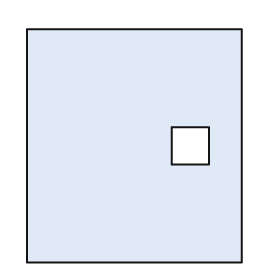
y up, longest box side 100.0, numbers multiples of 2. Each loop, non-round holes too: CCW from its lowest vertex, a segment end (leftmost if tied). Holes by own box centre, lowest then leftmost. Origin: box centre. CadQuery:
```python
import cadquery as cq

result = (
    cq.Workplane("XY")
    .moveTo(-46.0, -50.0)
    .lineTo(46.0, -50.0)
    .lineTo(46.0, 50.0)
    .lineTo(-46.0, 50.0)
    .close()
    .moveTo(16.0, -8.0)
    .lineTo(32.0, -8.0)
    .lineTo(32.0, 8.0)
    .lineTo(16.0, 8.0)
    .close()
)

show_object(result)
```